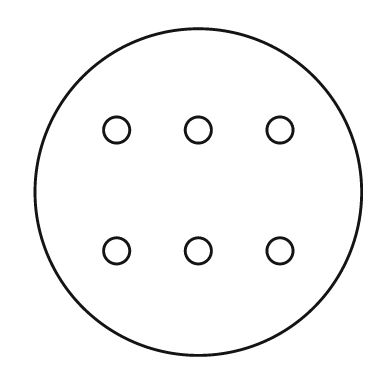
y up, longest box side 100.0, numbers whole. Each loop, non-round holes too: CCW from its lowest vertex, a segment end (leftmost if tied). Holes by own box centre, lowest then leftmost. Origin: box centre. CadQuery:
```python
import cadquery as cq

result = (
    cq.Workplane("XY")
    .moveTo(0.0, 0.0)
    .circle(50.0)
    .moveTo(-25.0, -18.0)
    .circle(4.0)
    .moveTo(0.0, -18.0)
    .circle(4.0)
    .moveTo(25.0, -18.0)
    .circle(4.0)
    .moveTo(-25.0, 19.0)
    .circle(4.0)
    .moveTo(0.0, 19.0)
    .circle(4.0)
    .moveTo(25.0, 19.0)
    .circle(4.0)
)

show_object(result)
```